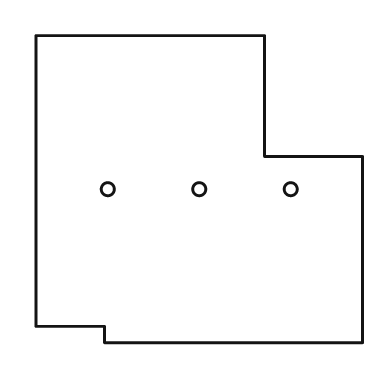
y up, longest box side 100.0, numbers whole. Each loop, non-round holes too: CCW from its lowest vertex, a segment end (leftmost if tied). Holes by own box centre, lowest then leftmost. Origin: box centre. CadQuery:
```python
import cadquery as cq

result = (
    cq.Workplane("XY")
    .moveTo(-29.0, -47.0)
    .lineTo(50.0, -47.0)
    .lineTo(50.0, 10.0)
    .lineTo(20.0, 10.0)
    .lineTo(20.0, 47.0)
    .lineTo(-50.0, 47.0)
    .lineTo(-50.0, -42.0)
    .lineTo(-29.0, -42.0)
    .close()
    .moveTo(-28.0, 0.0)
    .circle(2.0)
    .moveTo(0.0, 0.0)
    .circle(2.0)
    .moveTo(28.0, 0.0)
    .circle(2.0)
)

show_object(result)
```